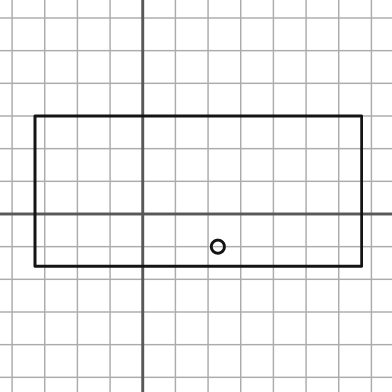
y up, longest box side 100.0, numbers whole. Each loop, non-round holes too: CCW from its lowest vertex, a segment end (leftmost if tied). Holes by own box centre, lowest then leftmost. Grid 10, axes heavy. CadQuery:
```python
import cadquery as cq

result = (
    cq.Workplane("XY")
    .moveTo(-33.0, -16.0)
    .lineTo(67.0, -16.0)
    .lineTo(67.0, 30.0)
    .lineTo(-33.0, 30.0)
    .close()
    .moveTo(23.0, -10.0)
    .circle(2.0)
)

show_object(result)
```